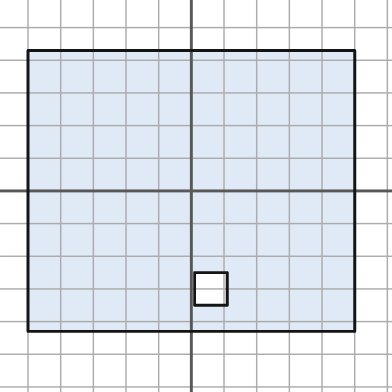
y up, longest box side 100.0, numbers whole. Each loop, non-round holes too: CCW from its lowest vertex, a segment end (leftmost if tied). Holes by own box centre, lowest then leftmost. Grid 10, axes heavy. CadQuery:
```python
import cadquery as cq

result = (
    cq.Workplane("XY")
    .moveTo(-50.0, -43.0)
    .lineTo(50.0, -43.0)
    .lineTo(50.0, 43.0)
    .lineTo(-50.0, 43.0)
    .close()
    .moveTo(1.0, -35.0)
    .lineTo(11.0, -35.0)
    .lineTo(11.0, -25.0)
    .lineTo(1.0, -25.0)
    .close()
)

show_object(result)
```